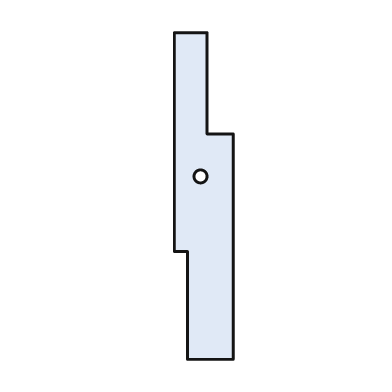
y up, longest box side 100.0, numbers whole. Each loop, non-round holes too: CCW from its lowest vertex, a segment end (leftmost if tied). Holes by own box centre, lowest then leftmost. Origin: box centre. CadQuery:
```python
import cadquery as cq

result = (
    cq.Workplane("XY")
    .moveTo(-5.0, -50.0)
    .lineTo(9.0, -50.0)
    .lineTo(9.0, 19.0)
    .lineTo(1.0, 19.0)
    .lineTo(1.0, 50.0)
    .lineTo(-9.0, 50.0)
    .lineTo(-9.0, -17.0)
    .lineTo(-5.0, -17.0)
    .close()
    .moveTo(-1.0, 6.0)
    .circle(2.0)
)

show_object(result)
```